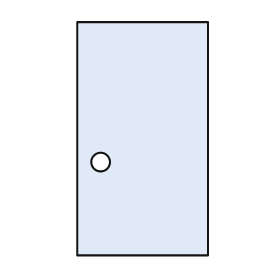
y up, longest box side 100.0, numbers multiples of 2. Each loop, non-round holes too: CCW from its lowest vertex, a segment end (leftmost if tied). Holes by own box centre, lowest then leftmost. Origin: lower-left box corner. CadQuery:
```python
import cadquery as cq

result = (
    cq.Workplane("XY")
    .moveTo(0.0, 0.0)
    .lineTo(56.0, 0.0)
    .lineTo(56.0, 100.0)
    .lineTo(0.0, 100.0)
    .close()
    .moveTo(10.0, 40.0)
    .circle(4.0)
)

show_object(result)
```